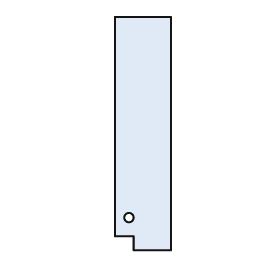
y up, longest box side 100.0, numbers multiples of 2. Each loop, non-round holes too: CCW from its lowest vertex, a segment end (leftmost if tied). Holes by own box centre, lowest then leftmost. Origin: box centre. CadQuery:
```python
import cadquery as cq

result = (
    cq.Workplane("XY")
    .moveTo(-4.0, -50.0)
    .lineTo(12.0, -50.0)
    .lineTo(12.0, 50.0)
    .lineTo(-12.0, 50.0)
    .lineTo(-12.0, -44.0)
    .lineTo(-4.0, -44.0)
    .close()
    .moveTo(-6.0, -36.0)
    .circle(2.0)
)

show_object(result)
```